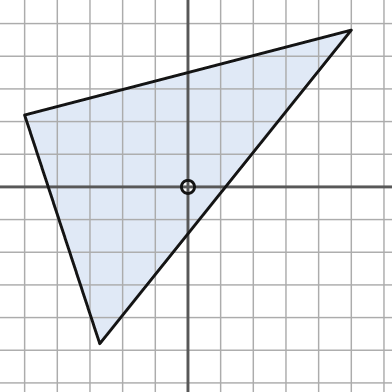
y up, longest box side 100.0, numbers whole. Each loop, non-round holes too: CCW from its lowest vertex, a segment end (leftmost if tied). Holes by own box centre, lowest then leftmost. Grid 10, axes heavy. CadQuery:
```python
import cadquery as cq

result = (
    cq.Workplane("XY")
    .moveTo(-27.0, -48.0)
    .lineTo(50.0, 48.0)
    .lineTo(-50.0, 22.0)
    .close()
    .moveTo(0.0, 0.0)
    .circle(2.0)
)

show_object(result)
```